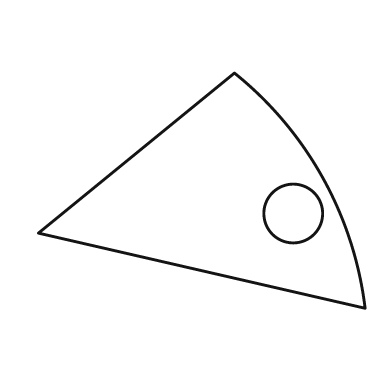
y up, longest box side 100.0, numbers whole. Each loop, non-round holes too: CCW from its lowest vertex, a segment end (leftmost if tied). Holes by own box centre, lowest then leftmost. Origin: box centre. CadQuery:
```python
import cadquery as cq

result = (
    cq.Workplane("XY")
    .moveTo(50.0, -36.0)
    .threePointArc((37.0, 4.0), (10.0, 36.0))
    .lineTo(-50.0, -13.0)
    .close()
    .moveTo(28.0, -7.0)
    .circle(9.0)
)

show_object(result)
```